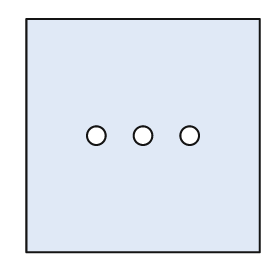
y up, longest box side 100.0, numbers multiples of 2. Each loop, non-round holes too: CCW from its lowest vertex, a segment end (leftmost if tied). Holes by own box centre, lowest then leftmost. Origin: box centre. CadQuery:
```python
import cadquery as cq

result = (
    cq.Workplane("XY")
    .moveTo(-50.0, -50.0)
    .lineTo(50.0, -50.0)
    .lineTo(50.0, 50.0)
    .lineTo(-50.0, 50.0)
    .close()
    .moveTo(-20.0, 0.0)
    .circle(4.0)
    .moveTo(0.0, 0.0)
    .circle(4.0)
    .moveTo(20.0, 0.0)
    .circle(4.0)
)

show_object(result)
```